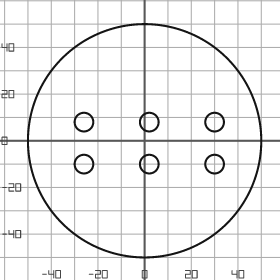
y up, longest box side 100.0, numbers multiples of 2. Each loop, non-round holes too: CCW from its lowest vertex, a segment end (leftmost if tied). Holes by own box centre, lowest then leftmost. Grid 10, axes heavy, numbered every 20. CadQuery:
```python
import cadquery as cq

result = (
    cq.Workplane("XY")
    .moveTo(0.0, 0.0)
    .circle(50.0)
    .moveTo(-26.0, -10.0)
    .circle(4.0)
    .moveTo(2.0, -10.0)
    .circle(4.0)
    .moveTo(30.0, -10.0)
    .circle(4.0)
    .moveTo(-26.0, 8.0)
    .circle(4.0)
    .moveTo(2.0, 8.0)
    .circle(4.0)
    .moveTo(30.0, 8.0)
    .circle(4.0)
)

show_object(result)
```